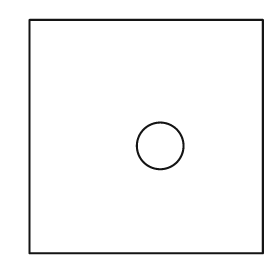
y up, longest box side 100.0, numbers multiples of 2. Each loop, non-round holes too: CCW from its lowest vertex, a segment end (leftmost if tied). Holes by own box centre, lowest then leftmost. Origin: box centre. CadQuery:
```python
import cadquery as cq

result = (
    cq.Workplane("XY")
    .moveTo(-50.0, -50.0)
    .lineTo(50.0, -50.0)
    .lineTo(50.0, 50.0)
    .lineTo(-50.0, 50.0)
    .close()
    .moveTo(6.0, -4.0)
    .circle(10.0)
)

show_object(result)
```